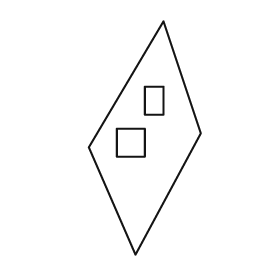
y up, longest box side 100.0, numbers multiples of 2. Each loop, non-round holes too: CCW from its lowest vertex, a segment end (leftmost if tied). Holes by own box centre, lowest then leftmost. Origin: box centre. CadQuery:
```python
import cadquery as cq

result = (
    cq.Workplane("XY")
    .moveTo(-4.0, -50.0)
    .lineTo(24.0, 2.0)
    .lineTo(8.0, 50.0)
    .lineTo(-24.0, -4.0)
    .close()
    .moveTo(-12.0, -8.0)
    .lineTo(0.0, -8.0)
    .lineTo(0.0, 4.0)
    .lineTo(-12.0, 4.0)
    .close()
    .moveTo(0.0, 10.0)
    .lineTo(8.0, 10.0)
    .lineTo(8.0, 22.0)
    .lineTo(0.0, 22.0)
    .close()
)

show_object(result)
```